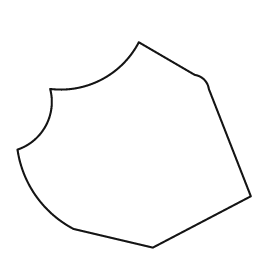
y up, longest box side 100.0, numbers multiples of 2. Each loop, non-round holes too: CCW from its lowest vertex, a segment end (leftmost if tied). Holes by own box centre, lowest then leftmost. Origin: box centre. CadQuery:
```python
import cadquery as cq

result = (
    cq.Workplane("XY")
    .moveTo(8.0, -44.0)
    .lineTo(50.0, -22.0)
    .lineTo(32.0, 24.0)
    .threePointArc((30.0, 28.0), (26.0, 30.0))
    .lineTo(2.0, 44.0)
    .threePointArc((-14.0, 28.0), (-36.0, 24.0))
    .threePointArc((-38.0, 8.0), (-50.0, -2.0))
    .threePointArc((-42.0, -22.0), (-26.0, -36.0))
    .close()
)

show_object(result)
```